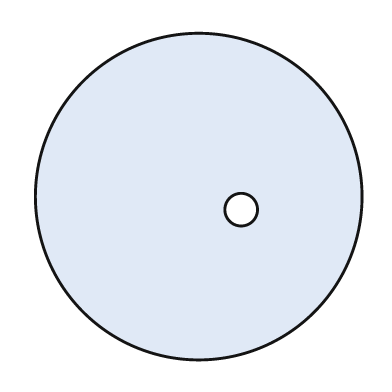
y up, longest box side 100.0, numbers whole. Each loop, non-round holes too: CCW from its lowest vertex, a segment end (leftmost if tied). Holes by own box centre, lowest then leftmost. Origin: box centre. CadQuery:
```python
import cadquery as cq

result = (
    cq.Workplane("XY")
    .moveTo(0.0, 0.0)
    .circle(50.0)
    .moveTo(13.0, -4.0)
    .circle(5.0)
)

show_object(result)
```